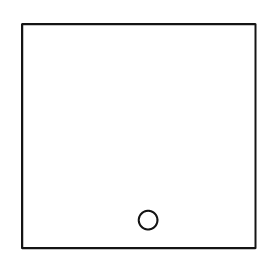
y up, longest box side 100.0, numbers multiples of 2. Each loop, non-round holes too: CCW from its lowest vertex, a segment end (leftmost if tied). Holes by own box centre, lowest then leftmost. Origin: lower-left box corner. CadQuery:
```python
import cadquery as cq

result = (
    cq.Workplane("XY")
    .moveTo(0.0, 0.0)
    .lineTo(100.0, 0.0)
    .lineTo(100.0, 96.0)
    .lineTo(0.0, 96.0)
    .close()
    .moveTo(54.0, 12.0)
    .circle(4.0)
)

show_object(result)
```